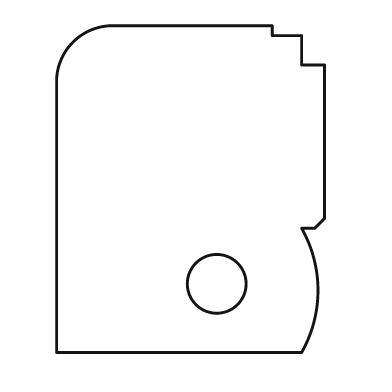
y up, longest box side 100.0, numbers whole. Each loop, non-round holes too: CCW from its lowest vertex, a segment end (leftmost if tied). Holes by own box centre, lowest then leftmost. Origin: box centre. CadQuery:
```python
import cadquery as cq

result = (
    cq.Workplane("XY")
    .moveTo(-41.0, -50.0)
    .lineTo(34.0, -50.0)
    .threePointArc((39.0, -31.0), (34.0, -12.0))
    .lineTo(38.0, -12.0)
    .lineTo(41.0, -9.0)
    .lineTo(41.0, 38.0)
    .lineTo(34.0, 38.0)
    .lineTo(34.0, 47.0)
    .lineTo(25.0, 47.0)
    .lineTo(25.0, 50.0)
    .lineTo(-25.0, 50.0)
    .threePointArc((-36.0, 45.0), (-41.0, 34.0))
    .close()
    .moveTo(8.0, -29.0)
    .circle(9.0)
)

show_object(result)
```